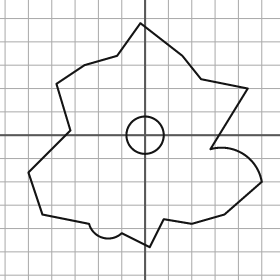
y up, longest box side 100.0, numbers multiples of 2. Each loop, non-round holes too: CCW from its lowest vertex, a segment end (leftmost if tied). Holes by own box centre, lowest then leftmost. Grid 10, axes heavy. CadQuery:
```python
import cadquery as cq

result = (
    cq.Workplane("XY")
    .moveTo(2.0, -48.0)
    .lineTo(8.0, -36.0)
    .lineTo(20.0, -38.0)
    .lineTo(34.0, -34.0)
    .lineTo(50.0, -20.0)
    .threePointArc((42.0, -8.0), (28.0, -6.0))
    .lineTo(44.0, 20.0)
    .lineTo(24.0, 24.0)
    .lineTo(16.0, 34.0)
    .lineTo(-2.0, 48.0)
    .lineTo(-12.0, 34.0)
    .lineTo(-26.0, 30.0)
    .lineTo(-38.0, 22.0)
    .lineTo(-32.0, 2.0)
    .lineTo(-50.0, -16.0)
    .lineTo(-44.0, -34.0)
    .lineTo(-24.0, -38.0)
    .threePointArc((-18.0, -44.0), (-10.0, -42.0))
    .close()
    .moveTo(0.0, 0.0)
    .circle(8.0)
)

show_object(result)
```